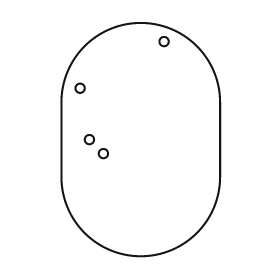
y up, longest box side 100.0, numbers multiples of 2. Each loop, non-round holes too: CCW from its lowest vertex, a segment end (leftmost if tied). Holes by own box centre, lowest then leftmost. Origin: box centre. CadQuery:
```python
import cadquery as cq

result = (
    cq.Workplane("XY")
    .moveTo(-34.0, -16.0)
    .threePointArc((0.0, -50.0), (34.0, -16.0))
    .lineTo(34.0, 16.0)
    .threePointArc((0.0, 50.0), (-34.0, 16.0))
    .close()
    .moveTo(-16.0, -6.0)
    .circle(2.0)
    .moveTo(-22.0, 0.0)
    .circle(2.0)
    .moveTo(-26.0, 22.0)
    .circle(2.0)
    .moveTo(10.0, 42.0)
    .circle(2.0)
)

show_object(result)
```